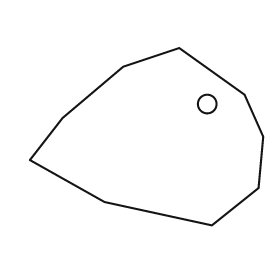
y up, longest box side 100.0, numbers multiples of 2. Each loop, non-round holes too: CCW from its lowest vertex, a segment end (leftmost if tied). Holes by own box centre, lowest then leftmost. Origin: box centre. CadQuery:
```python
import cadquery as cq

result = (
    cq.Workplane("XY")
    .moveTo(28.0, -38.0)
    .lineTo(48.0, -22.0)
    .lineTo(50.0, 0.0)
    .lineTo(42.0, 18.0)
    .lineTo(14.0, 38.0)
    .lineTo(-10.0, 30.0)
    .lineTo(-36.0, 8.0)
    .lineTo(-50.0, -10.0)
    .lineTo(-18.0, -28.0)
    .close()
    .moveTo(26.0, 14.0)
    .circle(4.0)
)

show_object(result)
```